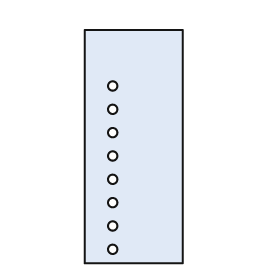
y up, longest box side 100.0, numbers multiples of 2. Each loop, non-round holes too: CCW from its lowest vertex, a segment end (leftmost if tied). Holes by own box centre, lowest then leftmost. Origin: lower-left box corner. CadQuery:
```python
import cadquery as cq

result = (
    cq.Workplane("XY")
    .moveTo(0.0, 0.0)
    .lineTo(42.0, 0.0)
    .lineTo(42.0, 100.0)
    .lineTo(0.0, 100.0)
    .close()
    .moveTo(12.0, 6.0)
    .circle(2.0)
    .moveTo(12.0, 16.0)
    .circle(2.0)
    .moveTo(12.0, 26.0)
    .circle(2.0)
    .moveTo(12.0, 36.0)
    .circle(2.0)
    .moveTo(12.0, 46.0)
    .circle(2.0)
    .moveTo(12.0, 56.0)
    .circle(2.0)
    .moveTo(12.0, 66.0)
    .circle(2.0)
    .moveTo(12.0, 76.0)
    .circle(2.0)
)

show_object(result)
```